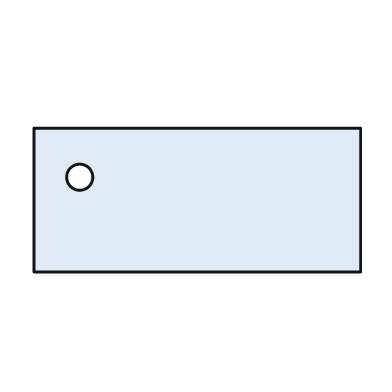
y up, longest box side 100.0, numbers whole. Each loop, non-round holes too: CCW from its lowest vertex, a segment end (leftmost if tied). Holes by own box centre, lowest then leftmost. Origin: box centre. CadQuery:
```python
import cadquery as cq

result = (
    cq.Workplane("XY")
    .moveTo(-50.0, -22.0)
    .lineTo(50.0, -22.0)
    .lineTo(50.0, 22.0)
    .lineTo(-50.0, 22.0)
    .close()
    .moveTo(-36.0, 7.0)
    .circle(4.0)
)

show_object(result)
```